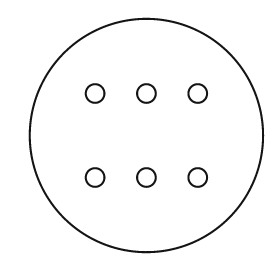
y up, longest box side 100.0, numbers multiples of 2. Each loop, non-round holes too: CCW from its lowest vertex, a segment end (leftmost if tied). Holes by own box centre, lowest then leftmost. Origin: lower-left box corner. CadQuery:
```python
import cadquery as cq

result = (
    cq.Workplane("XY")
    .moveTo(50.0, 50.0)
    .circle(50.0)
    .moveTo(28.0, 32.0)
    .circle(4.0)
    .moveTo(50.0, 32.0)
    .circle(4.0)
    .moveTo(72.0, 32.0)
    .circle(4.0)
    .moveTo(28.0, 68.0)
    .circle(4.0)
    .moveTo(50.0, 68.0)
    .circle(4.0)
    .moveTo(72.0, 68.0)
    .circle(4.0)
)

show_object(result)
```